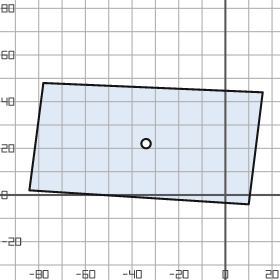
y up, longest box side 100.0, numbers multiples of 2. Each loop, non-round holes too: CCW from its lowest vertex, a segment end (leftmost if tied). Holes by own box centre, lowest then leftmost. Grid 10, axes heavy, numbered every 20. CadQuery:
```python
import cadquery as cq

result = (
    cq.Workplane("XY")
    .moveTo(10.0, -4.0)
    .lineTo(16.0, 44.0)
    .lineTo(-78.0, 48.0)
    .lineTo(-84.0, 2.0)
    .close()
    .moveTo(-34.0, 22.0)
    .circle(2.0)
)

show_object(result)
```